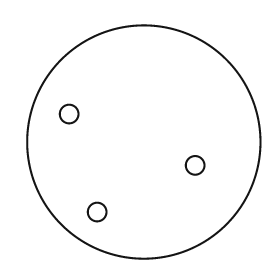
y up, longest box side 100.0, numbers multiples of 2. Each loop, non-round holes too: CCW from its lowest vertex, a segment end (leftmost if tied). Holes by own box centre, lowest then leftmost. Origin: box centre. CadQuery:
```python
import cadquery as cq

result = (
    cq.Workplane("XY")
    .moveTo(0.0, 0.0)
    .circle(50.0)
    .moveTo(-20.0, -30.0)
    .circle(4.0)
    .moveTo(22.0, -10.0)
    .circle(4.0)
    .moveTo(-32.0, 12.0)
    .circle(4.0)
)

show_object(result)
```